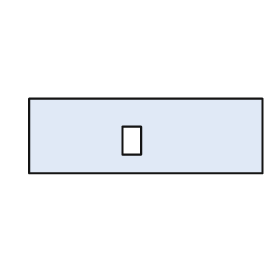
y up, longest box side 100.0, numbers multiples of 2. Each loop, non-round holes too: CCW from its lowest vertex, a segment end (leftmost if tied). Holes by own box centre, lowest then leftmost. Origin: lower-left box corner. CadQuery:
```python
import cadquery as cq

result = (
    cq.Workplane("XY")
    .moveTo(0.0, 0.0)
    .lineTo(100.0, 0.0)
    .lineTo(100.0, 32.0)
    .lineTo(0.0, 32.0)
    .close()
    .moveTo(40.0, 8.0)
    .lineTo(48.0, 8.0)
    .lineTo(48.0, 20.0)
    .lineTo(40.0, 20.0)
    .close()
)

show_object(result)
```